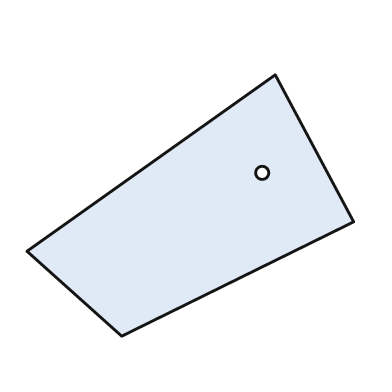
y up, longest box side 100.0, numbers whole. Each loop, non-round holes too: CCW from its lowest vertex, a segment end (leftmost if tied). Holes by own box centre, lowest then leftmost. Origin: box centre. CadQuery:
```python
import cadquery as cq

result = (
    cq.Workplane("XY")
    .moveTo(-21.0, -40.0)
    .lineTo(50.0, -5.0)
    .lineTo(26.0, 40.0)
    .lineTo(-50.0, -14.0)
    .close()
    .moveTo(22.0, 10.0)
    .circle(2.0)
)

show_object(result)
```